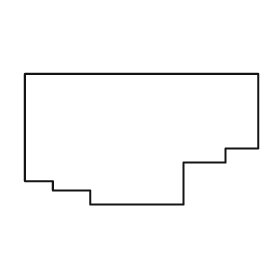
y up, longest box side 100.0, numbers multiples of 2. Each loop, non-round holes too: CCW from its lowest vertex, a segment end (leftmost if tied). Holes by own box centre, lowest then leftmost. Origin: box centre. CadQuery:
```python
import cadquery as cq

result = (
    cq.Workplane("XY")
    .moveTo(-22.0, -28.0)
    .lineTo(18.0, -28.0)
    .lineTo(18.0, -10.0)
    .lineTo(36.0, -10.0)
    .lineTo(36.0, -4.0)
    .lineTo(50.0, -4.0)
    .lineTo(50.0, 28.0)
    .lineTo(-50.0, 28.0)
    .lineTo(-50.0, -18.0)
    .lineTo(-38.0, -18.0)
    .lineTo(-38.0, -22.0)
    .lineTo(-22.0, -22.0)
    .close()
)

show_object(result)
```